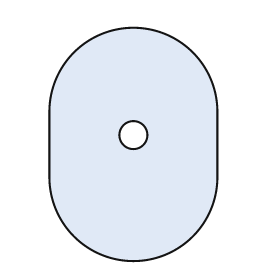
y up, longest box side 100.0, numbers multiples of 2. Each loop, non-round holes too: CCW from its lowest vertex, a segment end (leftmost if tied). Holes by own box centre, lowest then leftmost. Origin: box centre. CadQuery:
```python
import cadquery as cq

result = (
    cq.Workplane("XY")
    .moveTo(-36.0, -14.0)
    .threePointArc((0.0, -50.0), (36.0, -14.0))
    .lineTo(36.0, 14.0)
    .threePointArc((0.0, 50.0), (-36.0, 14.0))
    .close()
    .moveTo(0.0, 4.0)
    .circle(6.0)
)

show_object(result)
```